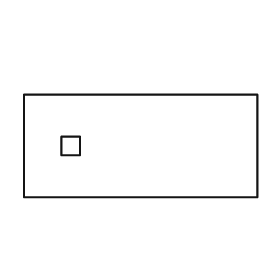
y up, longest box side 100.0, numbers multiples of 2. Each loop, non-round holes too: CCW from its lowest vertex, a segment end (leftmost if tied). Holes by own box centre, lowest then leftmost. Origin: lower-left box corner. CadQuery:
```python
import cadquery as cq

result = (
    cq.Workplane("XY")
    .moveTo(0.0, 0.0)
    .lineTo(100.0, 0.0)
    .lineTo(100.0, 44.0)
    .lineTo(0.0, 44.0)
    .close()
    .moveTo(16.0, 18.0)
    .lineTo(24.0, 18.0)
    .lineTo(24.0, 26.0)
    .lineTo(16.0, 26.0)
    .close()
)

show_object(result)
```